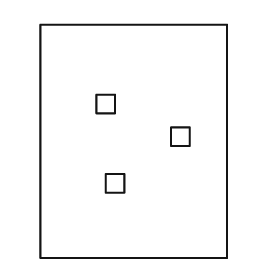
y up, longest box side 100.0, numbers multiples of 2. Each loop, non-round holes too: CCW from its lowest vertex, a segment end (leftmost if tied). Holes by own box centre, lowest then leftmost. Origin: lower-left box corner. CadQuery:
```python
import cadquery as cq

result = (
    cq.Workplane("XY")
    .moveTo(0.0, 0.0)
    .lineTo(80.0, 0.0)
    .lineTo(80.0, 100.0)
    .lineTo(0.0, 100.0)
    .close()
    .moveTo(28.0, 28.0)
    .lineTo(36.0, 28.0)
    .lineTo(36.0, 36.0)
    .lineTo(28.0, 36.0)
    .close()
    .moveTo(56.0, 48.0)
    .lineTo(64.0, 48.0)
    .lineTo(64.0, 56.0)
    .lineTo(56.0, 56.0)
    .close()
    .moveTo(24.0, 62.0)
    .lineTo(32.0, 62.0)
    .lineTo(32.0, 70.0)
    .lineTo(24.0, 70.0)
    .close()
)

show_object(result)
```